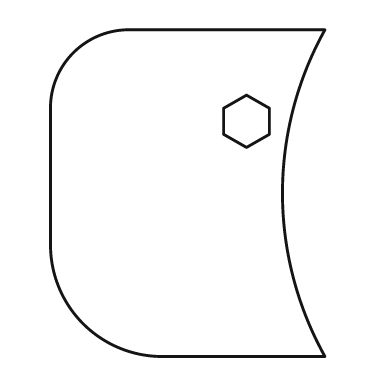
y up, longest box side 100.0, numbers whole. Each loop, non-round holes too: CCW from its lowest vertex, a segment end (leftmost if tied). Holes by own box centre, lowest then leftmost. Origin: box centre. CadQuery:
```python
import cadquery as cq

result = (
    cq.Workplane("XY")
    .moveTo(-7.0, -50.0)
    .lineTo(42.0, -50.0)
    .threePointArc((29.0, 0.0), (42.0, 50.0))
    .lineTo(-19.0, 50.0)
    .threePointArc((-35.0, 43.0), (-42.0, 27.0))
    .lineTo(-42.0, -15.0)
    .threePointArc((-32.0, -40.0), (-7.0, -50.0))
    .close()
    .moveTo(18.0, 14.0)
    .lineTo(25.0, 18.0)
    .lineTo(25.0, 26.0)
    .lineTo(18.0, 30.0)
    .lineTo(11.0, 26.0)
    .lineTo(11.0, 18.0)
    .close()
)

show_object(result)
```